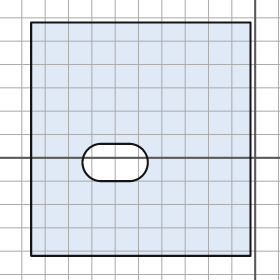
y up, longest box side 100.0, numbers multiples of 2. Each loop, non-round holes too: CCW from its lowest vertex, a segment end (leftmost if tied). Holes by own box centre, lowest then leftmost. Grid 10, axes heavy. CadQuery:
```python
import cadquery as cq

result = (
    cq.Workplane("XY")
    .moveTo(-96.0, -42.0)
    .lineTo(-2.0, -42.0)
    .lineTo(-2.0, 58.0)
    .lineTo(-96.0, 58.0)
    .close()
    .moveTo(-66.0, -10.0)
    .lineTo(-54.0, -10.0)
    .threePointArc((-46.0, -2.0), (-54.0, 6.0))
    .lineTo(-66.0, 6.0)
    .threePointArc((-74.0, -2.0), (-66.0, -10.0))
    .close()
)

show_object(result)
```